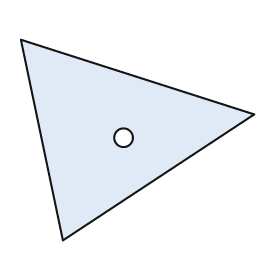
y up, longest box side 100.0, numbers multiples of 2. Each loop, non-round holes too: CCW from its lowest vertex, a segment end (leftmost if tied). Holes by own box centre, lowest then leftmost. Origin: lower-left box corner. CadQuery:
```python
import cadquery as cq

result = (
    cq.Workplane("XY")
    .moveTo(18.0, 0.0)
    .lineTo(100.0, 54.0)
    .lineTo(0.0, 86.0)
    .close()
    .moveTo(44.0, 44.0)
    .circle(4.0)
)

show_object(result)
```